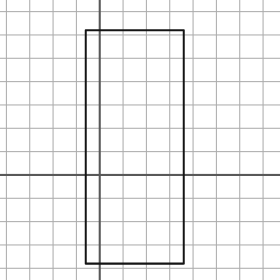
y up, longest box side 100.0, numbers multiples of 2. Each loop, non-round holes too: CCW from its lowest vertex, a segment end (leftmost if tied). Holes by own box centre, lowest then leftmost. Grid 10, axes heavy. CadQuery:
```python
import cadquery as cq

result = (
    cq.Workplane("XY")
    .moveTo(-6.0, -38.0)
    .lineTo(36.0, -38.0)
    .lineTo(36.0, 62.0)
    .lineTo(-6.0, 62.0)
    .close()
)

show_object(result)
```